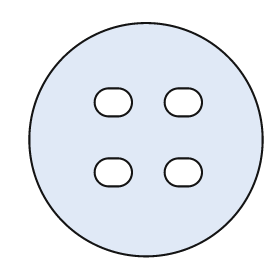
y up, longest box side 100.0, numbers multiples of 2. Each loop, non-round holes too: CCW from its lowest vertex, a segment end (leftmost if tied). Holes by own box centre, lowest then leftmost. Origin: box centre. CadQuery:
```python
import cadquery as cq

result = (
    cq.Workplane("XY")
    .moveTo(0.0, 0.0)
    .circle(50.0)
    .moveTo(-16.0, -20.0)
    .lineTo(-12.0, -20.0)
    .threePointArc((-6.0, -14.0), (-12.0, -8.0))
    .lineTo(-16.0, -8.0)
    .threePointArc((-22.0, -14.0), (-16.0, -20.0))
    .close()
    .moveTo(14.0, -20.0)
    .lineTo(18.0, -20.0)
    .threePointArc((24.0, -14.0), (18.0, -8.0))
    .lineTo(14.0, -8.0)
    .threePointArc((8.0, -14.0), (14.0, -20.0))
    .close()
    .moveTo(-16.0, 10.0)
    .lineTo(-12.0, 10.0)
    .threePointArc((-6.0, 16.0), (-12.0, 22.0))
    .lineTo(-16.0, 22.0)
    .threePointArc((-22.0, 16.0), (-16.0, 10.0))
    .close()
    .moveTo(14.0, 10.0)
    .lineTo(18.0, 10.0)
    .threePointArc((24.0, 16.0), (18.0, 22.0))
    .lineTo(14.0, 22.0)
    .threePointArc((8.0, 16.0), (14.0, 10.0))
    .close()
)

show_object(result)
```